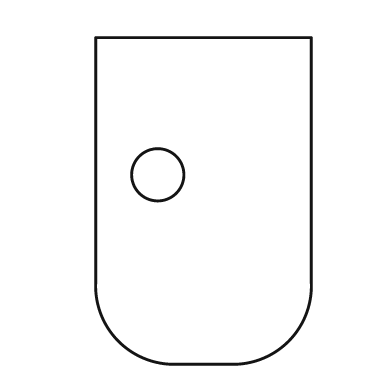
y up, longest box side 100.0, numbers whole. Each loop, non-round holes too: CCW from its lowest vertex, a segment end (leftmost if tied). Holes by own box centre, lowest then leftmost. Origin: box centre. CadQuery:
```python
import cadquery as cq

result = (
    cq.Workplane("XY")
    .moveTo(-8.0, -50.0)
    .lineTo(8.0, -50.0)
    .threePointArc((26.0, -43.0), (33.0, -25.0))
    .lineTo(33.0, 50.0)
    .lineTo(-33.0, 50.0)
    .lineTo(-33.0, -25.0)
    .threePointArc((-26.0, -43.0), (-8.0, -50.0))
    .close()
    .moveTo(-14.0, 8.0)
    .circle(8.0)
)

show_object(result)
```